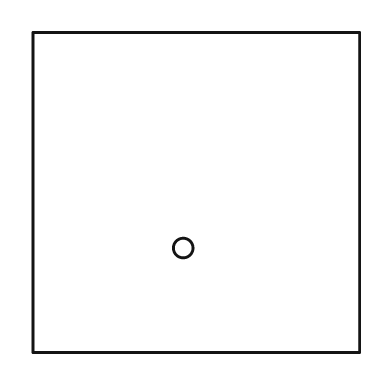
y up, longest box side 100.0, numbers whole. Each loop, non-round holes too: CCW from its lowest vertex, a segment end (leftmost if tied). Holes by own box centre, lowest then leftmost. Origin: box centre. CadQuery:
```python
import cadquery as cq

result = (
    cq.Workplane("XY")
    .moveTo(-50.0, -49.0)
    .lineTo(50.0, -49.0)
    .lineTo(50.0, 49.0)
    .lineTo(-50.0, 49.0)
    .close()
    .moveTo(-4.0, -17.0)
    .circle(3.0)
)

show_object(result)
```